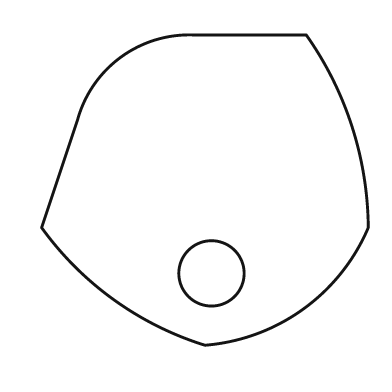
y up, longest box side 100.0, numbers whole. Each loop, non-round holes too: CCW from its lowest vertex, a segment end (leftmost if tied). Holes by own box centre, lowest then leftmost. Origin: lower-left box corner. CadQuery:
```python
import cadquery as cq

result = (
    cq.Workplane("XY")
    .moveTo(50.0, 0.0)
    .threePointArc((80.0, 11.0), (100.0, 36.0))
    .threePointArc((95.0, 67.0), (81.0, 95.0))
    .lineTo(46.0, 95.0)
    .threePointArc((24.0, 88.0), (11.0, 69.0))
    .lineTo(0.0, 36.0)
    .threePointArc((22.0, 14.0), (50.0, 0.0))
    .close()
    .moveTo(52.0, 22.0)
    .circle(10.0)
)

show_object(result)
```